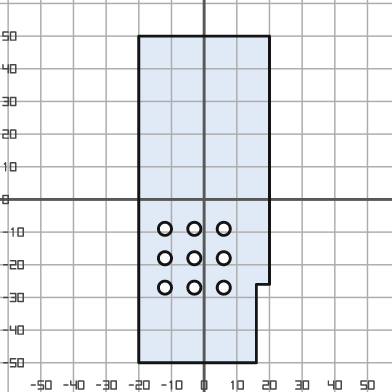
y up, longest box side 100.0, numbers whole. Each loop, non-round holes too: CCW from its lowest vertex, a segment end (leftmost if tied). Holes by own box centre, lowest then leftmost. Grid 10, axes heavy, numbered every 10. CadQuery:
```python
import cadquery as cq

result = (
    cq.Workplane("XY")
    .moveTo(-20.0, -50.0)
    .lineTo(16.0, -50.0)
    .lineTo(16.0, -26.0)
    .lineTo(20.0, -26.0)
    .lineTo(20.0, 50.0)
    .lineTo(-20.0, 50.0)
    .close()
    .moveTo(-12.0, -27.0)
    .circle(2.0)
    .moveTo(-3.0, -27.0)
    .circle(2.0)
    .moveTo(6.0, -27.0)
    .circle(2.0)
    .moveTo(-12.0, -18.0)
    .circle(2.0)
    .moveTo(-3.0, -18.0)
    .circle(2.0)
    .moveTo(6.0, -18.0)
    .circle(2.0)
    .moveTo(-12.0, -9.0)
    .circle(2.0)
    .moveTo(-3.0, -9.0)
    .circle(2.0)
    .moveTo(6.0, -9.0)
    .circle(2.0)
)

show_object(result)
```